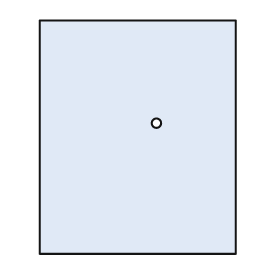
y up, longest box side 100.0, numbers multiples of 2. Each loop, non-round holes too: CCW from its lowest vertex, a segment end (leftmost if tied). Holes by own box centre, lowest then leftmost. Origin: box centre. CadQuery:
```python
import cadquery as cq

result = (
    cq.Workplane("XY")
    .moveTo(-42.0, -50.0)
    .lineTo(42.0, -50.0)
    .lineTo(42.0, 50.0)
    .lineTo(-42.0, 50.0)
    .close()
    .moveTo(8.0, 6.0)
    .circle(2.0)
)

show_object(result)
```